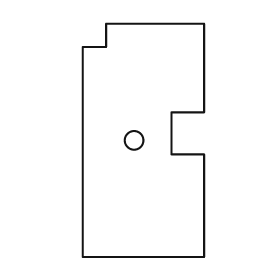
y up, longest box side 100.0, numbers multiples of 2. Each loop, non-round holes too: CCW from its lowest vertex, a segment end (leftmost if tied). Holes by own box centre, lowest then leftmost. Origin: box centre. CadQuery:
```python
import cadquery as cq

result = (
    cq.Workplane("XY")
    .moveTo(-26.0, -50.0)
    .lineTo(26.0, -50.0)
    .lineTo(26.0, -6.0)
    .lineTo(12.0, -6.0)
    .lineTo(12.0, 12.0)
    .lineTo(26.0, 12.0)
    .lineTo(26.0, 50.0)
    .lineTo(-16.0, 50.0)
    .lineTo(-16.0, 40.0)
    .lineTo(-26.0, 40.0)
    .close()
    .moveTo(-4.0, 0.0)
    .circle(4.0)
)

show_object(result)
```